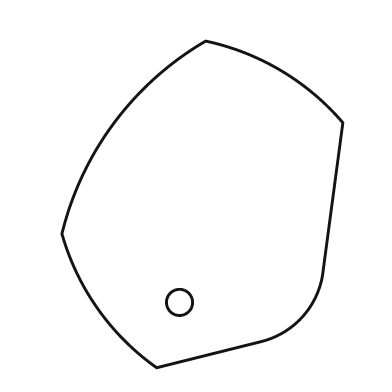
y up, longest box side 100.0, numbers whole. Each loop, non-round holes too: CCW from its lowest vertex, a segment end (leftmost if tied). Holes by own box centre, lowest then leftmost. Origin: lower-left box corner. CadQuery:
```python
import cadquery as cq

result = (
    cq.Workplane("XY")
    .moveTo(29.0, 0.0)
    .lineTo(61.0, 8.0)
    .threePointArc((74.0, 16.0), (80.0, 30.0))
    .lineTo(86.0, 75.0)
    .threePointArc((67.0, 91.0), (44.0, 100.0))
    .threePointArc((16.0, 75.0), (0.0, 41.0))
    .threePointArc((11.0, 18.0), (29.0, 0.0))
    .close()
    .moveTo(36.0, 20.0)
    .circle(4.0)
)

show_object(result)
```